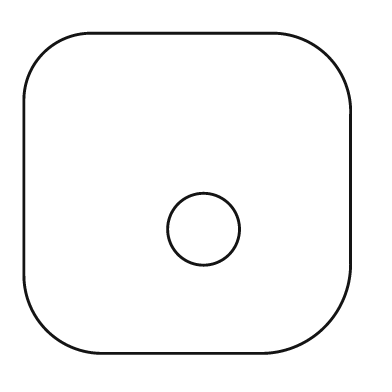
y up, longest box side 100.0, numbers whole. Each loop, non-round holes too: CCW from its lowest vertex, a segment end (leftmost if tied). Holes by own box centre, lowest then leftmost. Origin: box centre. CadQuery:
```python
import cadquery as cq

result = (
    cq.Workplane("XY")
    .moveTo(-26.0, -49.0)
    .lineTo(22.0, -49.0)
    .threePointArc((42.0, -41.0), (50.0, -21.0))
    .lineTo(50.0, 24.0)
    .threePointArc((43.0, 42.0), (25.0, 49.0))
    .lineTo(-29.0, 49.0)
    .threePointArc((-44.0, 43.0), (-50.0, 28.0))
    .lineTo(-50.0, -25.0)
    .threePointArc((-43.0, -42.0), (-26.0, -49.0))
    .close()
    .moveTo(5.0, -11.0)
    .circle(11.0)
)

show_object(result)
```